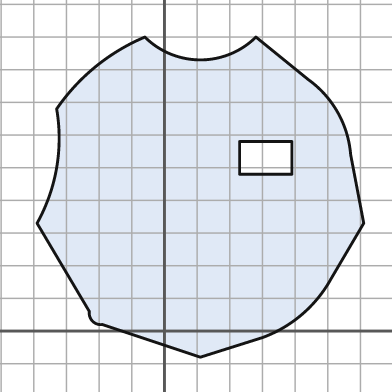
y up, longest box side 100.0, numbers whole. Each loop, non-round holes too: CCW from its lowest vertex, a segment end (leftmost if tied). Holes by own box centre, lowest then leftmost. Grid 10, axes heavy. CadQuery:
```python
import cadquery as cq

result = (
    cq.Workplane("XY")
    .moveTo(11.0, -8.0)
    .lineTo(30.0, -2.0)
    .threePointArc((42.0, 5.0), (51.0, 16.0))
    .lineTo(61.0, 33.0)
    .lineTo(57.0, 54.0)
    .threePointArc((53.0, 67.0), (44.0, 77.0))
    .lineTo(28.0, 90.0)
    .threePointArc((11.0, 83.0), (-6.0, 90.0))
    .threePointArc((-21.0, 81.0), (-33.0, 68.0))
    .threePointArc((-33.0, 50.0), (-39.0, 33.0))
    .lineTo(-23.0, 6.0)
    .threePointArc((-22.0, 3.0), (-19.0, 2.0))
    .close()
    .moveTo(23.0, 48.0)
    .lineTo(39.0, 48.0)
    .lineTo(39.0, 58.0)
    .lineTo(23.0, 58.0)
    .close()
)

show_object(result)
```